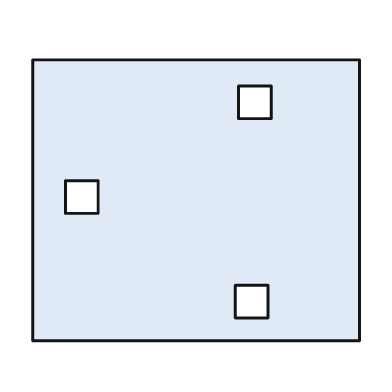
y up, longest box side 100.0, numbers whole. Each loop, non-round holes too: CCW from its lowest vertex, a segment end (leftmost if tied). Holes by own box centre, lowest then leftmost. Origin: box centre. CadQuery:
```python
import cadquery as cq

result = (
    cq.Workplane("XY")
    .moveTo(-50.0, -43.0)
    .lineTo(50.0, -43.0)
    .lineTo(50.0, 43.0)
    .lineTo(-50.0, 43.0)
    .close()
    .moveTo(12.0, -36.0)
    .lineTo(22.0, -36.0)
    .lineTo(22.0, -26.0)
    .lineTo(12.0, -26.0)
    .close()
    .moveTo(-40.0, -4.0)
    .lineTo(-30.0, -4.0)
    .lineTo(-30.0, 6.0)
    .lineTo(-40.0, 6.0)
    .close()
    .moveTo(13.0, 25.0)
    .lineTo(23.0, 25.0)
    .lineTo(23.0, 35.0)
    .lineTo(13.0, 35.0)
    .close()
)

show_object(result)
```